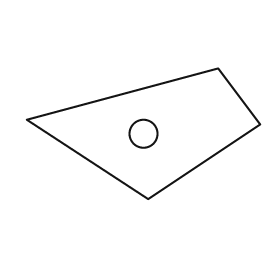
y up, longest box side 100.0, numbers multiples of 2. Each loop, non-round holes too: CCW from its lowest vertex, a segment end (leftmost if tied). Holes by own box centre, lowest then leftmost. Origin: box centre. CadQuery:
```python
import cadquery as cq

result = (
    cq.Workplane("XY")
    .moveTo(2.0, -28.0)
    .lineTo(50.0, 4.0)
    .lineTo(32.0, 28.0)
    .lineTo(-50.0, 6.0)
    .close()
    .moveTo(0.0, 0.0)
    .circle(6.0)
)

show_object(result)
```